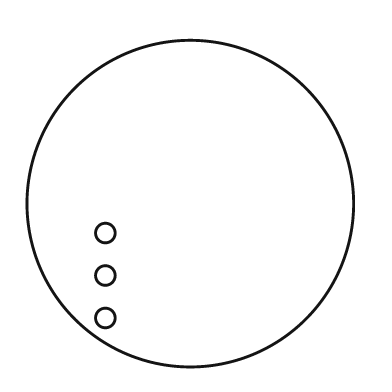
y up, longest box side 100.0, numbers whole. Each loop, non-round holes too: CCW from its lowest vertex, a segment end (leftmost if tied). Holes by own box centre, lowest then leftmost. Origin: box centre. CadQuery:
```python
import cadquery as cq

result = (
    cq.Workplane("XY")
    .moveTo(0.0, 0.0)
    .circle(50.0)
    .moveTo(-26.0, -35.0)
    .circle(3.0)
    .moveTo(-26.0, -22.0)
    .circle(3.0)
    .moveTo(-26.0, -9.0)
    .circle(3.0)
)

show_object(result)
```